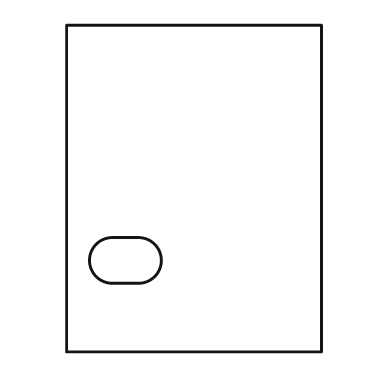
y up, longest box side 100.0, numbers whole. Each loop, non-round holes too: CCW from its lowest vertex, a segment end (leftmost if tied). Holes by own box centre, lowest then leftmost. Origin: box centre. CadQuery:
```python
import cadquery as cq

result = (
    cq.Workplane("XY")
    .moveTo(-39.0, -50.0)
    .lineTo(39.0, -50.0)
    .lineTo(39.0, 50.0)
    .lineTo(-39.0, 50.0)
    .close()
    .moveTo(-25.0, -29.0)
    .lineTo(-17.0, -29.0)
    .threePointArc((-10.0, -22.0), (-17.0, -15.0))
    .lineTo(-25.0, -15.0)
    .threePointArc((-32.0, -22.0), (-25.0, -29.0))
    .close()
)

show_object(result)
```